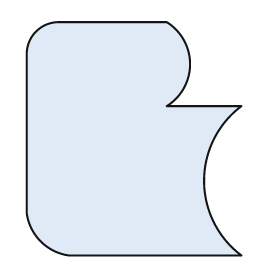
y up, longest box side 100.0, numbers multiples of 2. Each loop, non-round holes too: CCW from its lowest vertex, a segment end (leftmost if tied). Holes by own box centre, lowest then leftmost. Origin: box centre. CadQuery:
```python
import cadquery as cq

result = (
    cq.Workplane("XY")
    .moveTo(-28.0, -50.0)
    .lineTo(46.0, -50.0)
    .threePointArc((30.0, -18.0), (46.0, 14.0))
    .lineTo(14.0, 14.0)
    .threePointArc((24.0, 32.0), (14.0, 50.0))
    .lineTo(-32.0, 50.0)
    .threePointArc((-42.0, 46.0), (-46.0, 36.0))
    .lineTo(-46.0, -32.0)
    .threePointArc((-40.0, -44.0), (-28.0, -50.0))
    .close()
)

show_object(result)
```